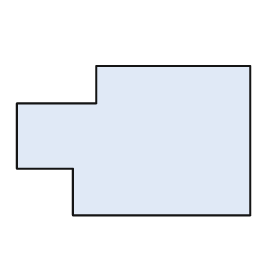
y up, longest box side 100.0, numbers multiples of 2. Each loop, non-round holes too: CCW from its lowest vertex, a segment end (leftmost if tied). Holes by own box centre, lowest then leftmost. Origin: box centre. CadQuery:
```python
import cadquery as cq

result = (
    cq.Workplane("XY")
    .moveTo(-26.0, -32.0)
    .lineTo(50.0, -32.0)
    .lineTo(50.0, 32.0)
    .lineTo(-16.0, 32.0)
    .lineTo(-16.0, 16.0)
    .lineTo(-50.0, 16.0)
    .lineTo(-50.0, -12.0)
    .lineTo(-26.0, -12.0)
    .close()
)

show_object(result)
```